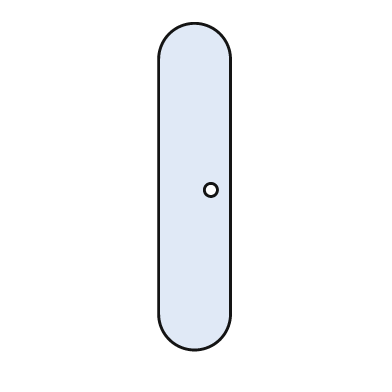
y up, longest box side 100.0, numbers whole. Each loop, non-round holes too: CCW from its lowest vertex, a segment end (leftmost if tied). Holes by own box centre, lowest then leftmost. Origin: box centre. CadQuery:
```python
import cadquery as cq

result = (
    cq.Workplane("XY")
    .moveTo(-11.0, -39.0)
    .threePointArc((0.0, -50.0), (11.0, -39.0))
    .lineTo(11.0, 39.0)
    .threePointArc((0.0, 50.0), (-11.0, 39.0))
    .close()
    .moveTo(5.0, -1.0)
    .circle(2.0)
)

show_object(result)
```